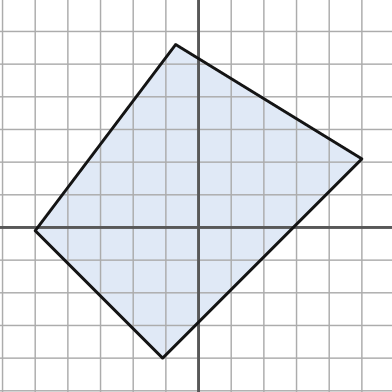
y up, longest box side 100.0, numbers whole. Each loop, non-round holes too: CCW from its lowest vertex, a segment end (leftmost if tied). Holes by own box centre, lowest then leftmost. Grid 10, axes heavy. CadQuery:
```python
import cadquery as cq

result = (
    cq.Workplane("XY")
    .moveTo(-11.0, -40.0)
    .lineTo(50.0, 21.0)
    .lineTo(-7.0, 56.0)
    .lineTo(-50.0, -1.0)
    .close()
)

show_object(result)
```